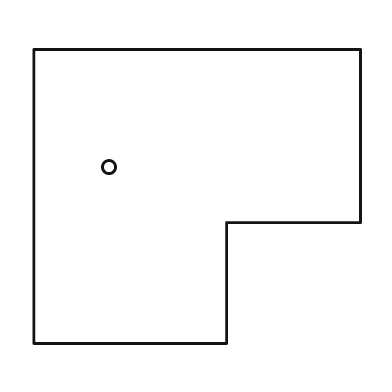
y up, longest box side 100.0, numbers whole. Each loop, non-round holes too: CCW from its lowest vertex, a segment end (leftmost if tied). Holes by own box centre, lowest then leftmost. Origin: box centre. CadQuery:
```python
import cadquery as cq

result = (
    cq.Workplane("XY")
    .moveTo(-50.0, -45.0)
    .lineTo(9.0, -45.0)
    .lineTo(9.0, -8.0)
    .lineTo(50.0, -8.0)
    .lineTo(50.0, 45.0)
    .lineTo(-50.0, 45.0)
    .close()
    .moveTo(-27.0, 9.0)
    .circle(2.0)
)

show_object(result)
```